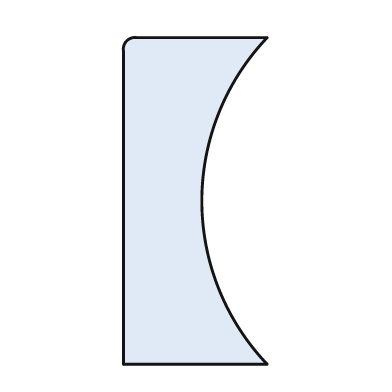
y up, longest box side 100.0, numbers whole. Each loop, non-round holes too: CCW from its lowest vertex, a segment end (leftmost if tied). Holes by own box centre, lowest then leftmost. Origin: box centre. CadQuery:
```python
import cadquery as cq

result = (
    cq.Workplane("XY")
    .moveTo(-22.0, -50.0)
    .lineTo(22.0, -50.0)
    .threePointArc((2.0, 0.0), (22.0, 50.0))
    .lineTo(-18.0, 50.0)
    .threePointArc((-21.0, 49.0), (-22.0, 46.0))
    .close()
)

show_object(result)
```